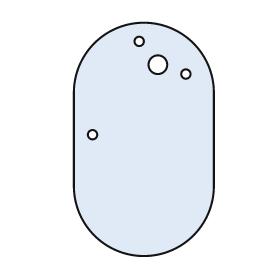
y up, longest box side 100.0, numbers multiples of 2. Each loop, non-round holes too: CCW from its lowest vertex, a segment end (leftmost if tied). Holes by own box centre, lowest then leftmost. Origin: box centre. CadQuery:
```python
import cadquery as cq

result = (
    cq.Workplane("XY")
    .moveTo(-30.0, -20.0)
    .threePointArc((0.0, -50.0), (30.0, -20.0))
    .lineTo(30.0, 20.0)
    .threePointArc((0.0, 50.0), (-30.0, 20.0))
    .close()
    .moveTo(-22.0, 2.0)
    .circle(2.0)
    .moveTo(18.0, 28.0)
    .circle(2.0)
    .moveTo(6.0, 32.0)
    .circle(4.0)
    .moveTo(-2.0, 42.0)
    .circle(2.0)
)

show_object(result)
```